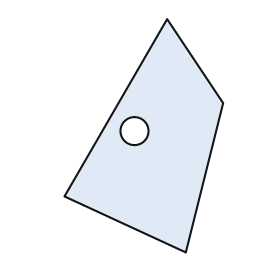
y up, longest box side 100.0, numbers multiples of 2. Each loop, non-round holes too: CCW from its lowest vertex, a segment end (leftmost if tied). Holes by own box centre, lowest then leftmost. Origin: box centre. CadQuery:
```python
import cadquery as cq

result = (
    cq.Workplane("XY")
    .moveTo(18.0, -50.0)
    .lineTo(34.0, 14.0)
    .lineTo(10.0, 50.0)
    .lineTo(-34.0, -26.0)
    .close()
    .moveTo(-4.0, 2.0)
    .circle(6.0)
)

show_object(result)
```